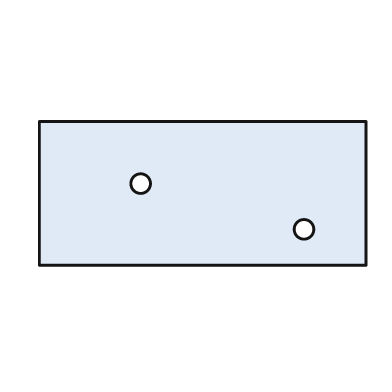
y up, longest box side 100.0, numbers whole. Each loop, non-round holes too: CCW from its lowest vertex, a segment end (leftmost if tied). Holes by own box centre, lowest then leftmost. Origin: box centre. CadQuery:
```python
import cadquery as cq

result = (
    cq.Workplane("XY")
    .moveTo(-50.0, -22.0)
    .lineTo(50.0, -22.0)
    .lineTo(50.0, 22.0)
    .lineTo(-50.0, 22.0)
    .close()
    .moveTo(31.0, -11.0)
    .circle(3.0)
    .moveTo(-19.0, 3.0)
    .circle(3.0)
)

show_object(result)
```